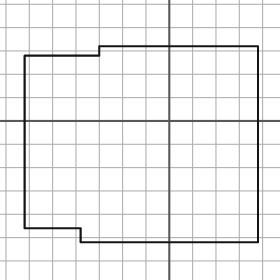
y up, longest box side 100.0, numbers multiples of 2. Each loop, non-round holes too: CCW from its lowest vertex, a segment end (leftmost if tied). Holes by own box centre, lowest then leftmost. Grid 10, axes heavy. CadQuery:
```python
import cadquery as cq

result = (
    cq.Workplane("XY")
    .moveTo(-38.0, -52.0)
    .lineTo(38.0, -52.0)
    .lineTo(38.0, 32.0)
    .lineTo(-30.0, 32.0)
    .lineTo(-30.0, 28.0)
    .lineTo(-62.0, 28.0)
    .lineTo(-62.0, -46.0)
    .lineTo(-38.0, -46.0)
    .close()
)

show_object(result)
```